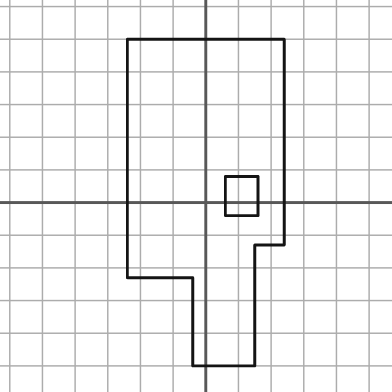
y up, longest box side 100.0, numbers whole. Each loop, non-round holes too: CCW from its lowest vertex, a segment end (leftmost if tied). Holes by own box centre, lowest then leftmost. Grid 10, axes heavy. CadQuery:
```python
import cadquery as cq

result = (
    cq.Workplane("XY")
    .moveTo(-4.0, -50.0)
    .lineTo(15.0, -50.0)
    .lineTo(15.0, -13.0)
    .lineTo(24.0, -13.0)
    .lineTo(24.0, 50.0)
    .lineTo(-24.0, 50.0)
    .lineTo(-24.0, -23.0)
    .lineTo(-4.0, -23.0)
    .close()
    .moveTo(6.0, -4.0)
    .lineTo(16.0, -4.0)
    .lineTo(16.0, 8.0)
    .lineTo(6.0, 8.0)
    .close()
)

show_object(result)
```